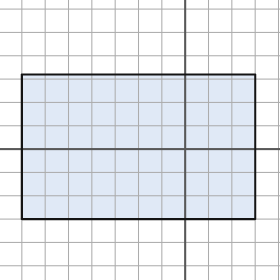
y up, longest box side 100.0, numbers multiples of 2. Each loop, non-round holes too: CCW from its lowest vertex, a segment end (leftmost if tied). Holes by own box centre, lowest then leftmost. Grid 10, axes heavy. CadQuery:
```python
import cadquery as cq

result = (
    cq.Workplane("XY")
    .moveTo(-70.0, -30.0)
    .lineTo(30.0, -30.0)
    .lineTo(30.0, 32.0)
    .lineTo(-70.0, 32.0)
    .close()
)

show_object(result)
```